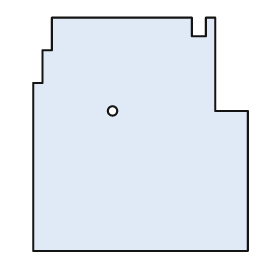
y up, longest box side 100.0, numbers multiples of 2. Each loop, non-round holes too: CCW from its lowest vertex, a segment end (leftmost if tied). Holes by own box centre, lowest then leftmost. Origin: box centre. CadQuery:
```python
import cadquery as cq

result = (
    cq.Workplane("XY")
    .moveTo(-46.0, -50.0)
    .lineTo(46.0, -50.0)
    .lineTo(46.0, 10.0)
    .lineTo(32.0, 10.0)
    .lineTo(32.0, 50.0)
    .lineTo(28.0, 50.0)
    .lineTo(28.0, 42.0)
    .lineTo(22.0, 42.0)
    .lineTo(22.0, 50.0)
    .lineTo(-38.0, 50.0)
    .lineTo(-38.0, 36.0)
    .lineTo(-42.0, 36.0)
    .lineTo(-42.0, 22.0)
    .lineTo(-46.0, 22.0)
    .close()
    .moveTo(-12.0, 10.0)
    .circle(2.0)
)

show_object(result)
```